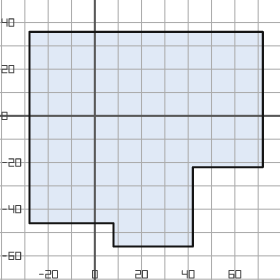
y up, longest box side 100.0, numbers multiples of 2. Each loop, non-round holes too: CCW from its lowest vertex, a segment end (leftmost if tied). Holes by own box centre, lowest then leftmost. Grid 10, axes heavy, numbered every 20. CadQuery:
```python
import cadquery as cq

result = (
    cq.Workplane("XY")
    .moveTo(8.0, -56.0)
    .lineTo(42.0, -56.0)
    .lineTo(42.0, -22.0)
    .lineTo(72.0, -22.0)
    .lineTo(72.0, 36.0)
    .lineTo(-28.0, 36.0)
    .lineTo(-28.0, -46.0)
    .lineTo(8.0, -46.0)
    .close()
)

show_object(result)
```